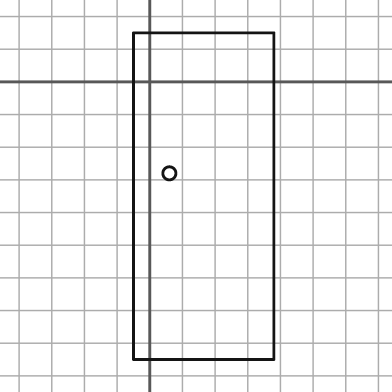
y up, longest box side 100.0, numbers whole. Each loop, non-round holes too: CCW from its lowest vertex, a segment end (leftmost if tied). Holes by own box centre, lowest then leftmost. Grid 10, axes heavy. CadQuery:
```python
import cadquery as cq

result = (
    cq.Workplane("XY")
    .moveTo(-5.0, -85.0)
    .lineTo(38.0, -85.0)
    .lineTo(38.0, 15.0)
    .lineTo(-5.0, 15.0)
    .close()
    .moveTo(6.0, -28.0)
    .circle(2.0)
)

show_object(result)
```